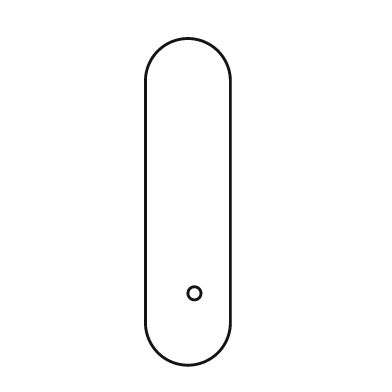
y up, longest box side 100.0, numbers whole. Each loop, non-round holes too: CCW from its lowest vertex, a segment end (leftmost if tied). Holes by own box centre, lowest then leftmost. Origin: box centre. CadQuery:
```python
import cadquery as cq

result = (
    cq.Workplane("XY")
    .moveTo(-13.0, -37.0)
    .threePointArc((0.0, -50.0), (13.0, -37.0))
    .lineTo(13.0, 37.0)
    .threePointArc((0.0, 50.0), (-13.0, 37.0))
    .close()
    .moveTo(2.0, -28.0)
    .circle(2.0)
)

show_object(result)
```